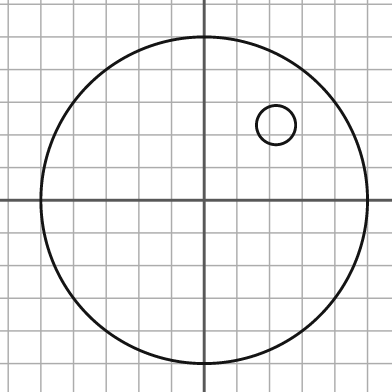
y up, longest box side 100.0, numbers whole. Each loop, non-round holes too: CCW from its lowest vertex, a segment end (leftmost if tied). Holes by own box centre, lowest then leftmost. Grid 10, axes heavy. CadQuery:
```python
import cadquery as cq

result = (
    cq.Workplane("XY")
    .moveTo(0.0, 0.0)
    .circle(50.0)
    .moveTo(22.0, 23.0)
    .circle(6.0)
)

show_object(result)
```